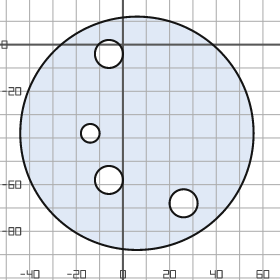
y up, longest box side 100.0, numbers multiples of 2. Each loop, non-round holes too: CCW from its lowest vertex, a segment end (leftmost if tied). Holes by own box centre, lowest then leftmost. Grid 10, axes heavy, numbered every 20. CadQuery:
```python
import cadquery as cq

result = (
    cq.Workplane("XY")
    .moveTo(6.0, -38.0)
    .circle(50.0)
    .moveTo(26.0, -68.0)
    .circle(6.0)
    .moveTo(-6.0, -58.0)
    .circle(6.0)
    .moveTo(-14.0, -38.0)
    .circle(4.0)
    .moveTo(-6.0, -4.0)
    .circle(6.0)
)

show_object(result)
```